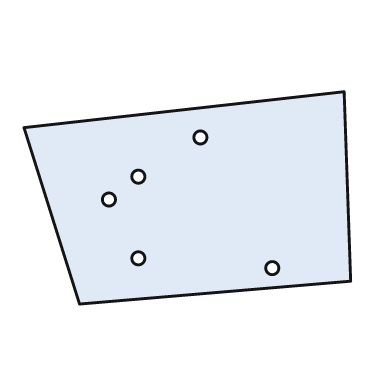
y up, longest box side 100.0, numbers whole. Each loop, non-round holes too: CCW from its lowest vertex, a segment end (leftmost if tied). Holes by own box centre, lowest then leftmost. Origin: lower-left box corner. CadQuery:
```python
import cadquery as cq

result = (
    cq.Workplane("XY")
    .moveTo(17.0, 0.0)
    .lineTo(100.0, 7.0)
    .lineTo(98.0, 65.0)
    .lineTo(0.0, 54.0)
    .close()
    .moveTo(76.0, 11.0)
    .circle(2.0)
    .moveTo(35.0, 14.0)
    .circle(2.0)
    .moveTo(26.0, 32.0)
    .circle(2.0)
    .moveTo(35.0, 39.0)
    .circle(2.0)
    .moveTo(54.0, 51.0)
    .circle(2.0)
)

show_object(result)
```